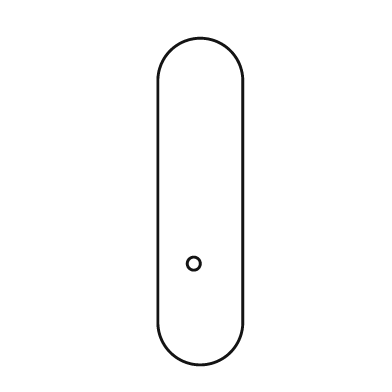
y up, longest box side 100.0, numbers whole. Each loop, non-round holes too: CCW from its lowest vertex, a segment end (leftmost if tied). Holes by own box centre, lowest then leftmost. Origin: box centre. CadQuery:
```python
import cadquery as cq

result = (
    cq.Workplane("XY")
    .moveTo(-13.0, -37.0)
    .threePointArc((0.0, -50.0), (13.0, -37.0))
    .lineTo(13.0, 37.0)
    .threePointArc((0.0, 50.0), (-13.0, 37.0))
    .close()
    .moveTo(-2.0, -19.0)
    .circle(2.0)
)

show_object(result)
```